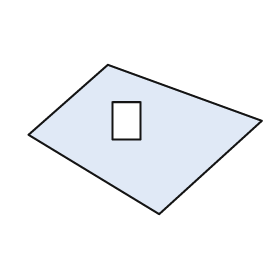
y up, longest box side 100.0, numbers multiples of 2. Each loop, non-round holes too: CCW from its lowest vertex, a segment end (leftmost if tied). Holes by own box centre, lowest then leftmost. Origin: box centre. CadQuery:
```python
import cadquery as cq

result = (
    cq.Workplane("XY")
    .moveTo(6.0, -32.0)
    .lineTo(50.0, 8.0)
    .lineTo(-16.0, 32.0)
    .lineTo(-50.0, 2.0)
    .close()
    .moveTo(-14.0, 0.0)
    .lineTo(-2.0, 0.0)
    .lineTo(-2.0, 16.0)
    .lineTo(-14.0, 16.0)
    .close()
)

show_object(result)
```